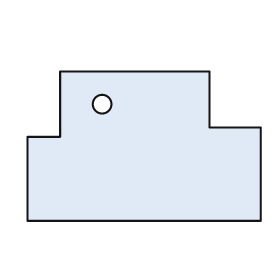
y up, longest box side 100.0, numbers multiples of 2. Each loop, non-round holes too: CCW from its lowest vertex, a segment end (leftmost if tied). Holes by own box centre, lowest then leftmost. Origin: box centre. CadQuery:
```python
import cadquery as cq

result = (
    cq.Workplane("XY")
    .moveTo(-50.0, -32.0)
    .lineTo(50.0, -32.0)
    .lineTo(50.0, 8.0)
    .lineTo(28.0, 8.0)
    .lineTo(28.0, 32.0)
    .lineTo(-36.0, 32.0)
    .lineTo(-36.0, 4.0)
    .lineTo(-50.0, 4.0)
    .close()
    .moveTo(-18.0, 18.0)
    .circle(4.0)
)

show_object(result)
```